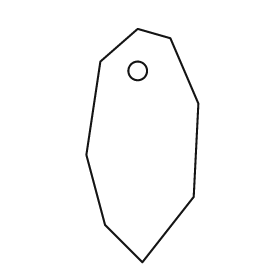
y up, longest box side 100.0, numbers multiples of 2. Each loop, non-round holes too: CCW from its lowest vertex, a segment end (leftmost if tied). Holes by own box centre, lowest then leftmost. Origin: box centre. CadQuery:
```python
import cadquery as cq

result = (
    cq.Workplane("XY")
    .moveTo(0.0, -50.0)
    .lineTo(22.0, -22.0)
    .lineTo(24.0, 18.0)
    .lineTo(12.0, 46.0)
    .lineTo(-2.0, 50.0)
    .lineTo(-18.0, 36.0)
    .lineTo(-24.0, -4.0)
    .lineTo(-16.0, -34.0)
    .close()
    .moveTo(-2.0, 32.0)
    .circle(4.0)
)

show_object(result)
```